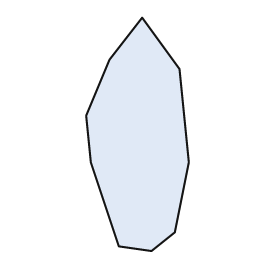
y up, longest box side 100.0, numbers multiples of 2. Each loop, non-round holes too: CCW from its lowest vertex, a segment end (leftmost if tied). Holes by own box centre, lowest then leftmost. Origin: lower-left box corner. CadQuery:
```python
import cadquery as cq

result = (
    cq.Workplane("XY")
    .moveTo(28.0, 0.0)
    .lineTo(38.0, 8.0)
    .lineTo(44.0, 38.0)
    .lineTo(40.0, 78.0)
    .lineTo(24.0, 100.0)
    .lineTo(10.0, 82.0)
    .lineTo(0.0, 58.0)
    .lineTo(2.0, 38.0)
    .lineTo(14.0, 2.0)
    .close()
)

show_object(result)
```